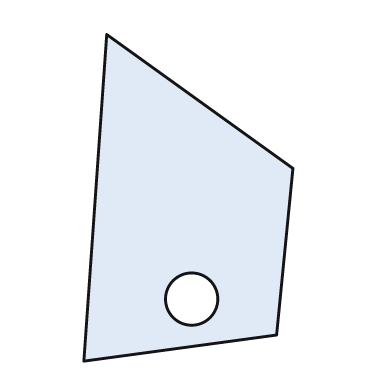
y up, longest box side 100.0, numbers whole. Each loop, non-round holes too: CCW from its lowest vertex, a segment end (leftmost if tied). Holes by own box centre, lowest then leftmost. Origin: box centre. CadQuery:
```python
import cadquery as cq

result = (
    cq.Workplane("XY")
    .moveTo(-32.0, -50.0)
    .lineTo(27.0, -42.0)
    .lineTo(32.0, 9.0)
    .lineTo(-25.0, 50.0)
    .close()
    .moveTo(1.0, -31.0)
    .circle(8.0)
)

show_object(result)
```